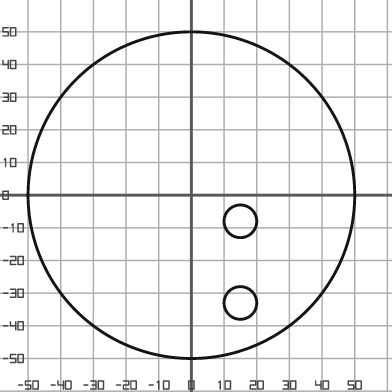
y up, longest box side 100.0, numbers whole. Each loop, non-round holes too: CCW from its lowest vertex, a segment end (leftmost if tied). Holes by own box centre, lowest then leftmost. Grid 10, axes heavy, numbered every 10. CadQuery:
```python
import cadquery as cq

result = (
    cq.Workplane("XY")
    .moveTo(0.0, 0.0)
    .circle(50.0)
    .moveTo(15.0, -33.0)
    .circle(5.0)
    .moveTo(15.0, -8.0)
    .circle(5.0)
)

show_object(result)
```